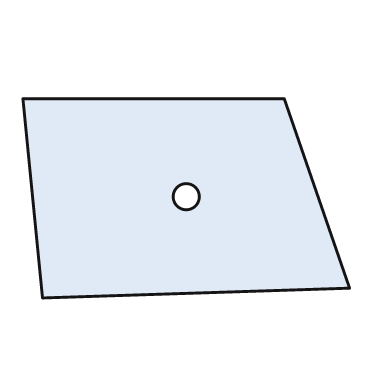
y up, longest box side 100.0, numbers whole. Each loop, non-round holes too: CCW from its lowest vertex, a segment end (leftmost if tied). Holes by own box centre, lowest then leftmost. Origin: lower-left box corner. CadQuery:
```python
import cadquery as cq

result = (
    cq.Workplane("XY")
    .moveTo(6.0, 0.0)
    .lineTo(100.0, 3.0)
    .lineTo(80.0, 61.0)
    .lineTo(0.0, 61.0)
    .close()
    .moveTo(50.0, 31.0)
    .circle(4.0)
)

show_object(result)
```